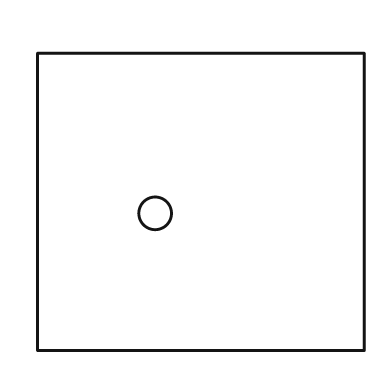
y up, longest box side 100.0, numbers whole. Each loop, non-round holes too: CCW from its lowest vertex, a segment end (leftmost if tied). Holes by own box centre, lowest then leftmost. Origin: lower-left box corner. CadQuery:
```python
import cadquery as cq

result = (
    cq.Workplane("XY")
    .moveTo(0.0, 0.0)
    .lineTo(100.0, 0.0)
    .lineTo(100.0, 91.0)
    .lineTo(0.0, 91.0)
    .close()
    .moveTo(36.0, 42.0)
    .circle(5.0)
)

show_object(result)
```